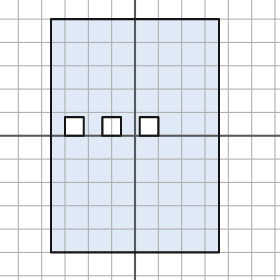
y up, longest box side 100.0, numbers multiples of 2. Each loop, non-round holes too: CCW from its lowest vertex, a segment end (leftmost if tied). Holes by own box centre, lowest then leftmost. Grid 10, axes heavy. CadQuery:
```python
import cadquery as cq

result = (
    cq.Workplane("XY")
    .moveTo(-36.0, -50.0)
    .lineTo(36.0, -50.0)
    .lineTo(36.0, 50.0)
    .lineTo(-36.0, 50.0)
    .close()
    .moveTo(-30.0, 0.0)
    .lineTo(-22.0, 0.0)
    .lineTo(-22.0, 8.0)
    .lineTo(-30.0, 8.0)
    .close()
    .moveTo(-14.0, 0.0)
    .lineTo(-6.0, 0.0)
    .lineTo(-6.0, 8.0)
    .lineTo(-14.0, 8.0)
    .close()
    .moveTo(2.0, 0.0)
    .lineTo(10.0, 0.0)
    .lineTo(10.0, 8.0)
    .lineTo(2.0, 8.0)
    .close()
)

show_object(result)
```